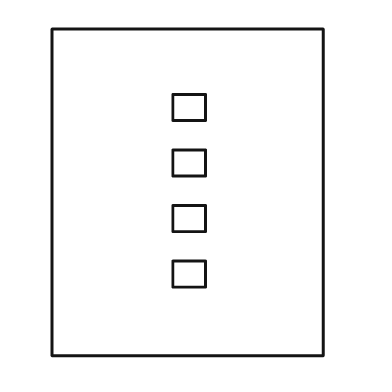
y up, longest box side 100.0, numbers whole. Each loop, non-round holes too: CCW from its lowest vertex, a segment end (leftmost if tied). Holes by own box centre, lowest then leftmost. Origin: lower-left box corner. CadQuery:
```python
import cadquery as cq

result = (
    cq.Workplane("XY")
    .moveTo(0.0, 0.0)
    .lineTo(83.0, 0.0)
    .lineTo(83.0, 100.0)
    .lineTo(0.0, 100.0)
    .close()
    .moveTo(37.0, 21.0)
    .lineTo(47.0, 21.0)
    .lineTo(47.0, 29.0)
    .lineTo(37.0, 29.0)
    .close()
    .moveTo(37.0, 38.0)
    .lineTo(47.0, 38.0)
    .lineTo(47.0, 46.0)
    .lineTo(37.0, 46.0)
    .close()
    .moveTo(37.0, 55.0)
    .lineTo(47.0, 55.0)
    .lineTo(47.0, 63.0)
    .lineTo(37.0, 63.0)
    .close()
    .moveTo(37.0, 72.0)
    .lineTo(47.0, 72.0)
    .lineTo(47.0, 80.0)
    .lineTo(37.0, 80.0)
    .close()
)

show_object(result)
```